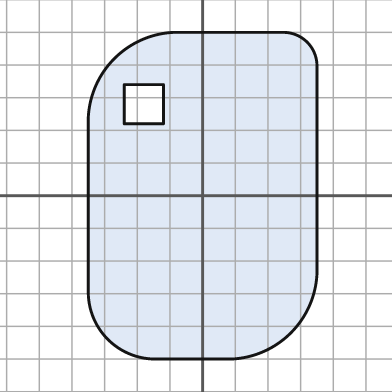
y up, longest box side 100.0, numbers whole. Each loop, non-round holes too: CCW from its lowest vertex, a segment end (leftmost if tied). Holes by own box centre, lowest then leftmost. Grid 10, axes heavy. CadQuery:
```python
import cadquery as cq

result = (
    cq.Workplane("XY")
    .moveTo(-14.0, -50.0)
    .lineTo(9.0, -50.0)
    .threePointArc((27.0, -42.0), (35.0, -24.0))
    .lineTo(35.0, 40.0)
    .threePointArc((32.0, 47.0), (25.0, 50.0))
    .lineTo(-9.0, 50.0)
    .threePointArc((-27.0, 42.0), (-35.0, 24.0))
    .lineTo(-35.0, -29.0)
    .threePointArc((-29.0, -44.0), (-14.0, -50.0))
    .close()
    .moveTo(-24.0, 22.0)
    .lineTo(-12.0, 22.0)
    .lineTo(-12.0, 34.0)
    .lineTo(-24.0, 34.0)
    .close()
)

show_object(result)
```